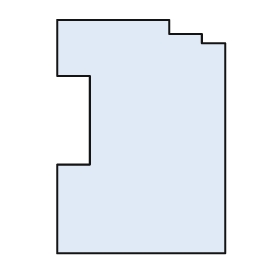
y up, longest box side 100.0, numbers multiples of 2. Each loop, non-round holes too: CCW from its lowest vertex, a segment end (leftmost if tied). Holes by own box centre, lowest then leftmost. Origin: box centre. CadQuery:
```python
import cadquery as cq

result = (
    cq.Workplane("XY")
    .moveTo(-36.0, -50.0)
    .lineTo(36.0, -50.0)
    .lineTo(36.0, 40.0)
    .lineTo(26.0, 40.0)
    .lineTo(26.0, 44.0)
    .lineTo(12.0, 44.0)
    .lineTo(12.0, 50.0)
    .lineTo(-36.0, 50.0)
    .lineTo(-36.0, 26.0)
    .lineTo(-22.0, 26.0)
    .lineTo(-22.0, -12.0)
    .lineTo(-36.0, -12.0)
    .close()
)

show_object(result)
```